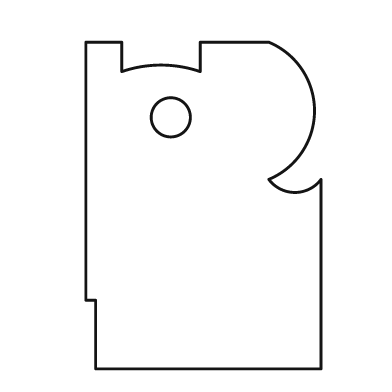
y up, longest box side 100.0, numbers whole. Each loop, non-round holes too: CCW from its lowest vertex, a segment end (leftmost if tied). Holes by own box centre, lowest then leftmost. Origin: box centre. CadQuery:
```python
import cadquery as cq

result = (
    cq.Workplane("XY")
    .moveTo(-33.0, -50.0)
    .lineTo(36.0, -50.0)
    .lineTo(36.0, 8.0)
    .threePointArc((28.0, 4.0), (20.0, 8.0))
    .threePointArc((34.0, 29.0), (20.0, 50.0))
    .lineTo(-1.0, 50.0)
    .lineTo(-1.0, 41.0)
    .threePointArc((-13.0, 43.0), (-25.0, 41.0))
    .lineTo(-25.0, 50.0)
    .lineTo(-36.0, 50.0)
    .lineTo(-36.0, -29.0)
    .lineTo(-33.0, -29.0)
    .close()
    .moveTo(-10.0, 27.0)
    .circle(6.0)
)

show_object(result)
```